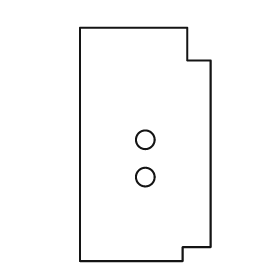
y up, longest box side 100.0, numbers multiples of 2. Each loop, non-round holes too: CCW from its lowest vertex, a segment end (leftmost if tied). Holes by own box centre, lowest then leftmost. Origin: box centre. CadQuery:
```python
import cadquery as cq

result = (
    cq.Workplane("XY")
    .moveTo(-28.0, -50.0)
    .lineTo(16.0, -50.0)
    .lineTo(16.0, -44.0)
    .lineTo(28.0, -44.0)
    .lineTo(28.0, 36.0)
    .lineTo(18.0, 36.0)
    .lineTo(18.0, 50.0)
    .lineTo(-28.0, 50.0)
    .close()
    .moveTo(0.0, -14.0)
    .circle(4.0)
    .moveTo(0.0, 2.0)
    .circle(4.0)
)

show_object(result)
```